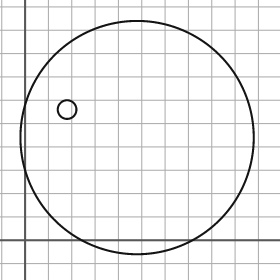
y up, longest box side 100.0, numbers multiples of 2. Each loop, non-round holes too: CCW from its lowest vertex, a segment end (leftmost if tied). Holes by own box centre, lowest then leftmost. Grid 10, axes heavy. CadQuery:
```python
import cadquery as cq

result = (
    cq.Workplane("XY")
    .moveTo(48.0, 44.0)
    .circle(50.0)
    .moveTo(18.0, 56.0)
    .circle(4.0)
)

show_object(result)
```